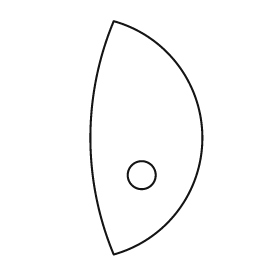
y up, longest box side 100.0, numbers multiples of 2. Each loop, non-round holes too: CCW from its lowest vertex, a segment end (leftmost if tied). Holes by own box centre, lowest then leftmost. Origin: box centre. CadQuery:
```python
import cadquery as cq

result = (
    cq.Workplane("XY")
    .moveTo(-14.0, -50.0)
    .threePointArc((24.0, 0.0), (-14.0, 50.0))
    .threePointArc((-24.0, 0.0), (-14.0, -50.0))
    .close()
    .moveTo(-2.0, -16.0)
    .circle(6.0)
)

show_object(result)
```